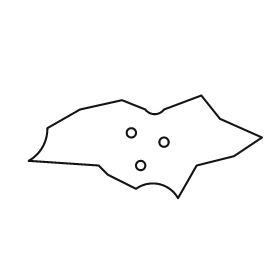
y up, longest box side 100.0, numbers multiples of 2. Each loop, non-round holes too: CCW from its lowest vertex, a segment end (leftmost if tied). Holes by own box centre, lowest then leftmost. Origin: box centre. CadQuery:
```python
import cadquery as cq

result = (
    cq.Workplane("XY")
    .moveTo(14.0, -22.0)
    .lineTo(22.0, -8.0)
    .lineTo(38.0, -4.0)
    .lineTo(50.0, 4.0)
    .lineTo(32.0, 12.0)
    .lineTo(24.0, 22.0)
    .lineTo(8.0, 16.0)
    .threePointArc((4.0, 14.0), (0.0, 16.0))
    .lineTo(-10.0, 20.0)
    .lineTo(-28.0, 16.0)
    .lineTo(-42.0, 8.0)
    .threePointArc((-44.0, 0.0), (-50.0, -6.0))
    .lineTo(-20.0, -8.0)
    .lineTo(-16.0, -12.0)
    .lineTo(-4.0, -18.0)
    .threePointArc((6.0, -16.0), (14.0, -22.0))
    .close()
    .moveTo(-2.0, -8.0)
    .circle(2.0)
    .moveTo(8.0, 2.0)
    .circle(2.0)
    .moveTo(-6.0, 6.0)
    .circle(2.0)
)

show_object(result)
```